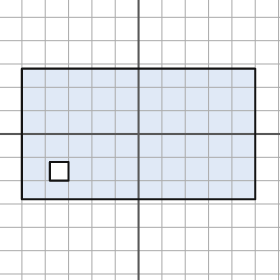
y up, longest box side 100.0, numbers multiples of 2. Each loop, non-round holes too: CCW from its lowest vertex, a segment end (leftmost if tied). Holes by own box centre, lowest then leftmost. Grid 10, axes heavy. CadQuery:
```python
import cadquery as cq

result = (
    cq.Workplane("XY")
    .moveTo(-50.0, -28.0)
    .lineTo(50.0, -28.0)
    .lineTo(50.0, 28.0)
    .lineTo(-50.0, 28.0)
    .close()
    .moveTo(-38.0, -20.0)
    .lineTo(-30.0, -20.0)
    .lineTo(-30.0, -12.0)
    .lineTo(-38.0, -12.0)
    .close()
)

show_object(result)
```